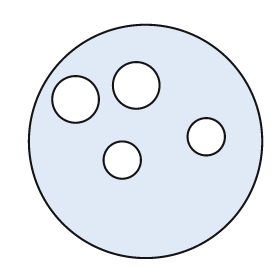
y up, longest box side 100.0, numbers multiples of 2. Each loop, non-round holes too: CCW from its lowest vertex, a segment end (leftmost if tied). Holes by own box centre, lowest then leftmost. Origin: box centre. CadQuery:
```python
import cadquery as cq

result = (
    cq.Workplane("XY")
    .moveTo(0.0, 0.0)
    .circle(50.0)
    .moveTo(-10.0, -8.0)
    .circle(8.0)
    .moveTo(26.0, 2.0)
    .circle(8.0)
    .moveTo(-30.0, 18.0)
    .circle(10.0)
    .moveTo(-4.0, 24.0)
    .circle(10.0)
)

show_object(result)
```